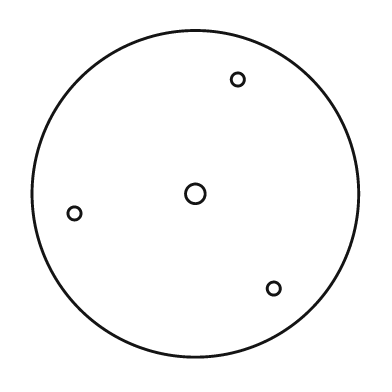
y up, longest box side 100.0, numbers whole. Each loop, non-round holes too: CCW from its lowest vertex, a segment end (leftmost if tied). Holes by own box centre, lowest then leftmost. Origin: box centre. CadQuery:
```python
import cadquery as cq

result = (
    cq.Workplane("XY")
    .moveTo(0.0, 0.0)
    .circle(50.0)
    .moveTo(24.0, -29.0)
    .circle(2.0)
    .moveTo(-37.0, -6.0)
    .circle(2.0)
    .moveTo(0.0, 0.0)
    .circle(3.0)
    .moveTo(13.0, 35.0)
    .circle(2.0)
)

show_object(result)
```